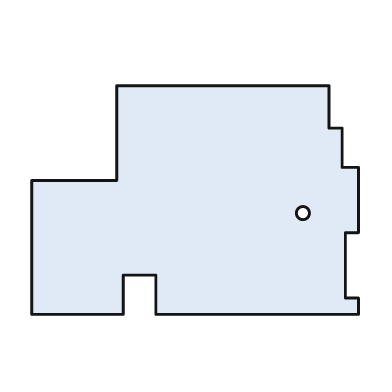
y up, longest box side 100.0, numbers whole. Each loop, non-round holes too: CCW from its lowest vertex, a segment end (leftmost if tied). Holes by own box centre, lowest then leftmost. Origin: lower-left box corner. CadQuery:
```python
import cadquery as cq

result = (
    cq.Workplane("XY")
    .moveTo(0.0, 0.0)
    .lineTo(28.0, 0.0)
    .lineTo(28.0, 12.0)
    .lineTo(38.0, 12.0)
    .lineTo(38.0, 0.0)
    .lineTo(100.0, 0.0)
    .lineTo(100.0, 5.0)
    .lineTo(96.0, 5.0)
    .lineTo(96.0, 25.0)
    .lineTo(100.0, 25.0)
    .lineTo(100.0, 45.0)
    .lineTo(95.0, 45.0)
    .lineTo(95.0, 57.0)
    .lineTo(91.0, 57.0)
    .lineTo(91.0, 70.0)
    .lineTo(26.0, 70.0)
    .lineTo(26.0, 41.0)
    .lineTo(0.0, 41.0)
    .close()
    .moveTo(83.0, 31.0)
    .circle(2.0)
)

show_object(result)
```